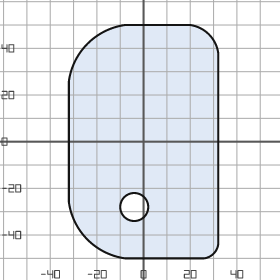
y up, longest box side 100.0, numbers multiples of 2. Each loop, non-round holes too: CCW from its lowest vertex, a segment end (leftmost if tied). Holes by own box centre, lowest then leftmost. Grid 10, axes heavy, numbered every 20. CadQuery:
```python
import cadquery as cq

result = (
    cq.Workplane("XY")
    .moveTo(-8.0, -50.0)
    .lineTo(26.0, -50.0)
    .threePointArc((30.0, -48.0), (32.0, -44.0))
    .lineTo(32.0, 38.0)
    .threePointArc((28.0, 46.0), (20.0, 50.0))
    .lineTo(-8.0, 50.0)
    .threePointArc((-24.0, 42.0), (-32.0, 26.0))
    .lineTo(-32.0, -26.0)
    .threePointArc((-24.0, -42.0), (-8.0, -50.0))
    .close()
    .moveTo(-4.0, -28.0)
    .circle(6.0)
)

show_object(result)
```